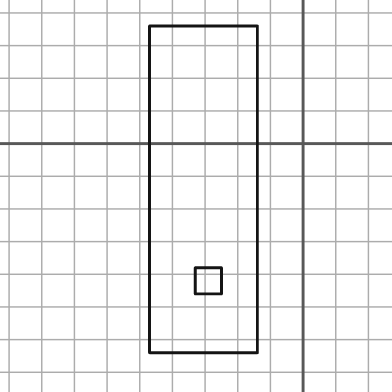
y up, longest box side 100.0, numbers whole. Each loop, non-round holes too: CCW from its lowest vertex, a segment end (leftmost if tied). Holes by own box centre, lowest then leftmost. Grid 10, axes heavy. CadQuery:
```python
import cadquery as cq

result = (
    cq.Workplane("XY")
    .moveTo(-47.0, -64.0)
    .lineTo(-14.0, -64.0)
    .lineTo(-14.0, 36.0)
    .lineTo(-47.0, 36.0)
    .close()
    .moveTo(-33.0, -46.0)
    .lineTo(-25.0, -46.0)
    .lineTo(-25.0, -38.0)
    .lineTo(-33.0, -38.0)
    .close()
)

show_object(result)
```